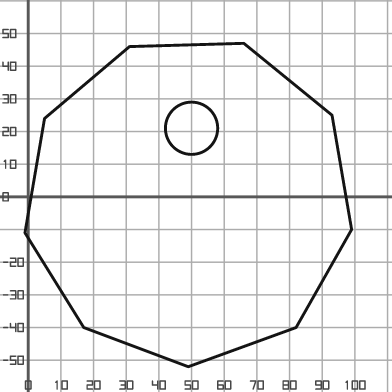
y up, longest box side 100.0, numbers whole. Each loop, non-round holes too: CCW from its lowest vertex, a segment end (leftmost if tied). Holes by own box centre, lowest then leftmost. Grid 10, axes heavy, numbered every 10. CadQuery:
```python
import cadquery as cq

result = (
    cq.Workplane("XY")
    .moveTo(49.0, -52.0)
    .lineTo(82.0, -40.0)
    .lineTo(99.0, -10.0)
    .lineTo(93.0, 25.0)
    .lineTo(66.0, 47.0)
    .lineTo(31.0, 46.0)
    .lineTo(5.0, 24.0)
    .lineTo(-1.0, -11.0)
    .lineTo(17.0, -40.0)
    .close()
    .moveTo(50.0, 21.0)
    .circle(8.0)
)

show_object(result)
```